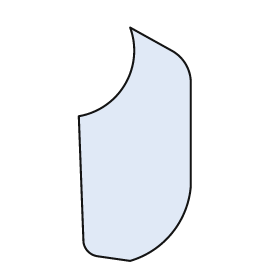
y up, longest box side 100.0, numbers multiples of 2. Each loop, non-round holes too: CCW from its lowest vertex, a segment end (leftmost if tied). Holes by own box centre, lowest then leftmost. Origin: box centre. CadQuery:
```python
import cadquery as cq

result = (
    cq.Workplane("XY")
    .moveTo(-2.0, -50.0)
    .threePointArc((16.0, -38.0), (24.0, -18.0))
    .lineTo(24.0, 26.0)
    .threePointArc((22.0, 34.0), (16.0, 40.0))
    .lineTo(-2.0, 50.0)
    .threePointArc((-4.0, 26.0), (-24.0, 12.0))
    .lineTo(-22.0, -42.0)
    .threePointArc((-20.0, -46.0), (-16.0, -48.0))
    .close()
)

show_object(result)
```